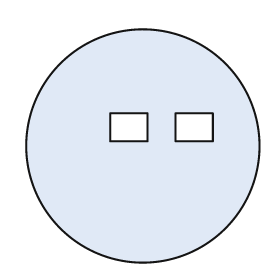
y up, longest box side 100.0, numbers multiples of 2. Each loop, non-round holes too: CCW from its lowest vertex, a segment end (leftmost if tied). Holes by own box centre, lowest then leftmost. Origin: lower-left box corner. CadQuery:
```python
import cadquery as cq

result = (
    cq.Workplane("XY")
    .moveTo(50.0, 50.0)
    .circle(50.0)
    .moveTo(36.0, 52.0)
    .lineTo(52.0, 52.0)
    .lineTo(52.0, 64.0)
    .lineTo(36.0, 64.0)
    .close()
    .moveTo(64.0, 52.0)
    .lineTo(80.0, 52.0)
    .lineTo(80.0, 64.0)
    .lineTo(64.0, 64.0)
    .close()
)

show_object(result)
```